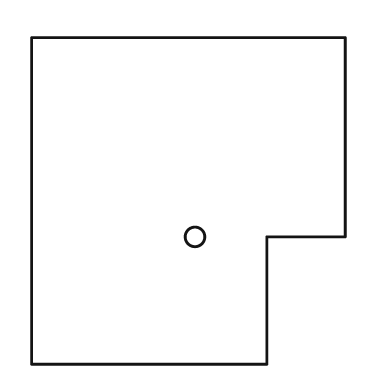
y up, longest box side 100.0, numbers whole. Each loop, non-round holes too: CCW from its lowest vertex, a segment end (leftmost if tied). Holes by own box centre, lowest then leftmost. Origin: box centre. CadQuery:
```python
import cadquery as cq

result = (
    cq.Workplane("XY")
    .moveTo(-48.0, -50.0)
    .lineTo(24.0, -50.0)
    .lineTo(24.0, -11.0)
    .lineTo(48.0, -11.0)
    .lineTo(48.0, 50.0)
    .lineTo(-48.0, 50.0)
    .close()
    .moveTo(2.0, -11.0)
    .circle(3.0)
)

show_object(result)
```